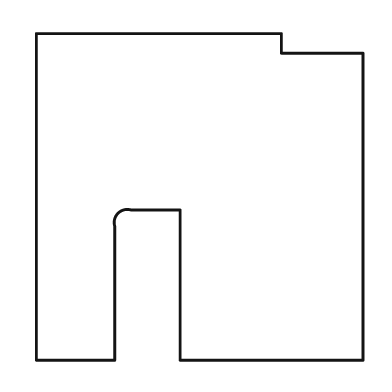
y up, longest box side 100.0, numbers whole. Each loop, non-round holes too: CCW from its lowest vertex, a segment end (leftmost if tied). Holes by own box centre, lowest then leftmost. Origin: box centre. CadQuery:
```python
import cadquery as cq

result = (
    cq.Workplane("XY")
    .moveTo(-50.0, -50.0)
    .lineTo(-26.0, -50.0)
    .lineTo(-26.0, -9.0)
    .threePointArc((-25.0, -5.0), (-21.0, -4.0))
    .lineTo(-6.0, -4.0)
    .lineTo(-6.0, -50.0)
    .lineTo(50.0, -50.0)
    .lineTo(50.0, 44.0)
    .lineTo(25.0, 44.0)
    .lineTo(25.0, 50.0)
    .lineTo(-50.0, 50.0)
    .close()
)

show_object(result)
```